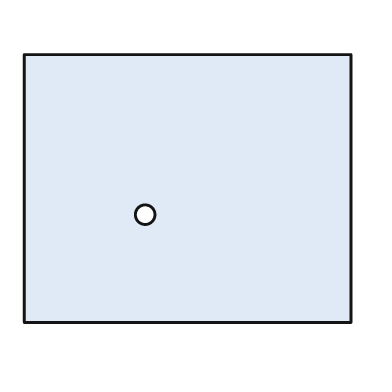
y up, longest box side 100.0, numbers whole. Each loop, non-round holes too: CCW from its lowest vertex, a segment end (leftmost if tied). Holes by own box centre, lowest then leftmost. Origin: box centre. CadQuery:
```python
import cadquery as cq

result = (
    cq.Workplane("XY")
    .moveTo(-50.0, -41.0)
    .lineTo(50.0, -41.0)
    .lineTo(50.0, 41.0)
    .lineTo(-50.0, 41.0)
    .close()
    .moveTo(-13.0, -8.0)
    .circle(3.0)
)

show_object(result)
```